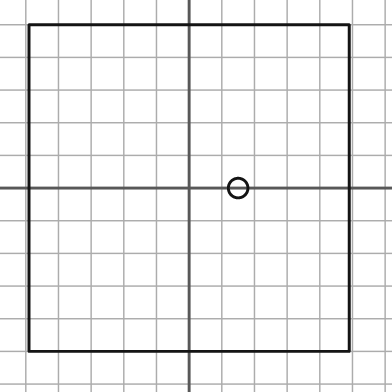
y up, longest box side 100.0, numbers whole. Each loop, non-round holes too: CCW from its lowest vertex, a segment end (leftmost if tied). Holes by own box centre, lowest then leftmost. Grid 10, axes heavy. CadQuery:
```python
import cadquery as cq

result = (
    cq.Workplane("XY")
    .moveTo(-49.0, -50.0)
    .lineTo(49.0, -50.0)
    .lineTo(49.0, 50.0)
    .lineTo(-49.0, 50.0)
    .close()
    .moveTo(15.0, 0.0)
    .circle(3.0)
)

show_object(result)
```